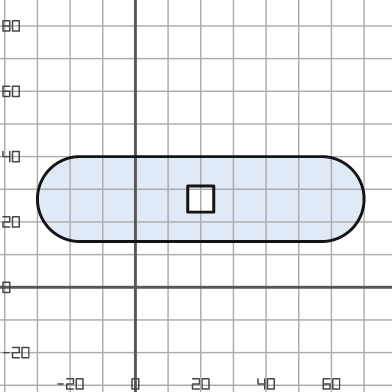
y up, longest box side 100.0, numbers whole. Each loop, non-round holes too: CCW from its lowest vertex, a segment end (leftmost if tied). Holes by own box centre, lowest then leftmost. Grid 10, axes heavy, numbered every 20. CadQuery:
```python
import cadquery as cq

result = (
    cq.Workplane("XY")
    .moveTo(-17.0, 14.0)
    .lineTo(57.0, 14.0)
    .threePointArc((70.0, 27.0), (57.0, 40.0))
    .lineTo(-17.0, 40.0)
    .threePointArc((-30.0, 27.0), (-17.0, 14.0))
    .close()
    .moveTo(16.0, 23.0)
    .lineTo(24.0, 23.0)
    .lineTo(24.0, 31.0)
    .lineTo(16.0, 31.0)
    .close()
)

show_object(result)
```